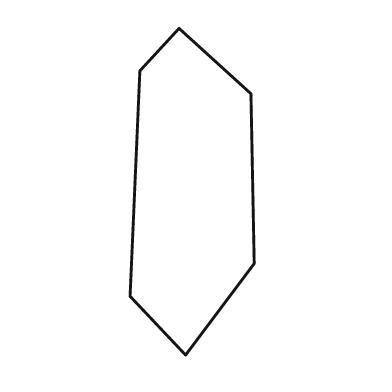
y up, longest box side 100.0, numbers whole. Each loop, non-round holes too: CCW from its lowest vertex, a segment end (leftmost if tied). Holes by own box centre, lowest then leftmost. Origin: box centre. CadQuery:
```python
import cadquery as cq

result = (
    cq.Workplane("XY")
    .moveTo(-2.0, -50.0)
    .lineTo(19.0, -22.0)
    .lineTo(18.0, 30.0)
    .lineTo(-4.0, 50.0)
    .lineTo(-16.0, 37.0)
    .lineTo(-19.0, -32.0)
    .close()
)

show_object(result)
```